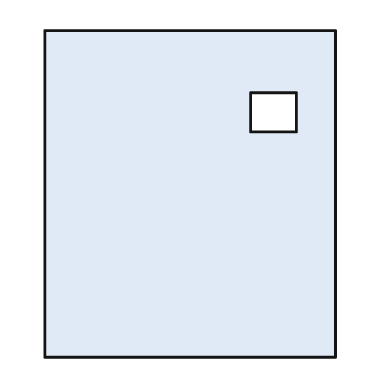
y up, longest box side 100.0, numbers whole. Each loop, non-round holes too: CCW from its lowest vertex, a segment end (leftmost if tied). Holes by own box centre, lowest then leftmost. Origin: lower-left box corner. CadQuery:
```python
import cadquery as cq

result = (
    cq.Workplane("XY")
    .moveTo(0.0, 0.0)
    .lineTo(89.0, 0.0)
    .lineTo(89.0, 100.0)
    .lineTo(0.0, 100.0)
    .close()
    .moveTo(63.0, 69.0)
    .lineTo(77.0, 69.0)
    .lineTo(77.0, 81.0)
    .lineTo(63.0, 81.0)
    .close()
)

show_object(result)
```